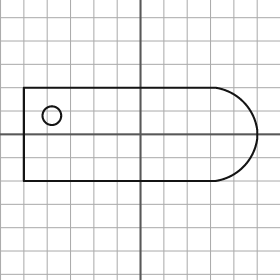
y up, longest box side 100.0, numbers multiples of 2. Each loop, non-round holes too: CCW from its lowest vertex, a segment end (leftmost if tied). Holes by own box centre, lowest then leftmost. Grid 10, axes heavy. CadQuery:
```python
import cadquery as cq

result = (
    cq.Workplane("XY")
    .moveTo(-50.0, -20.0)
    .lineTo(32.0, -20.0)
    .threePointArc((44.0, -14.0), (50.0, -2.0))
    .lineTo(50.0, 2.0)
    .threePointArc((44.0, 14.0), (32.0, 20.0))
    .lineTo(-50.0, 20.0)
    .close()
    .moveTo(-38.0, 8.0)
    .circle(4.0)
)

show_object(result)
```